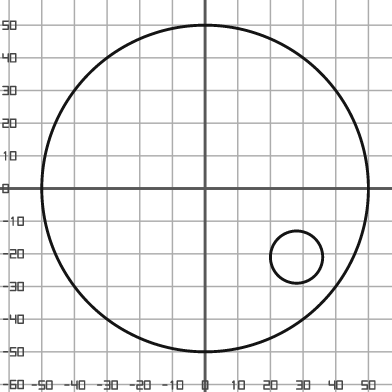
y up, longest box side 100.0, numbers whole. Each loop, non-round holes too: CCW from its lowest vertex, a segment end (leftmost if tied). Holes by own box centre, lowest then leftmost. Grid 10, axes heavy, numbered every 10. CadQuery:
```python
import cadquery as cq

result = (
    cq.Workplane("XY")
    .moveTo(0.0, 0.0)
    .circle(50.0)
    .moveTo(28.0, -21.0)
    .circle(8.0)
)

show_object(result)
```